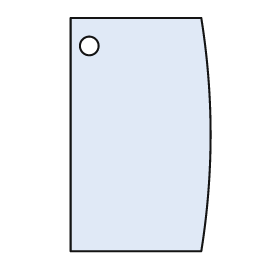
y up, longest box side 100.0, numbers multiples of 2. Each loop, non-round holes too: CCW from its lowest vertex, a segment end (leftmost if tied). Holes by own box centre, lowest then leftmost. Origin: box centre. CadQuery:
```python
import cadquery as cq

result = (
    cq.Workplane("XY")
    .moveTo(-30.0, -50.0)
    .lineTo(26.0, -50.0)
    .threePointArc((30.0, 0.0), (26.0, 50.0))
    .lineTo(-30.0, 50.0)
    .close()
    .moveTo(-22.0, 38.0)
    .circle(4.0)
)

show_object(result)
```